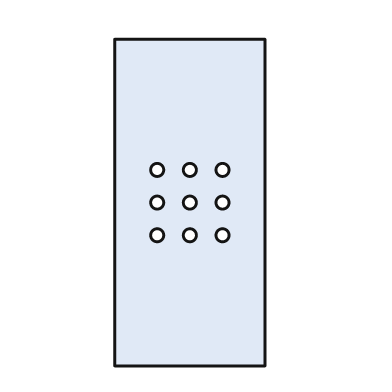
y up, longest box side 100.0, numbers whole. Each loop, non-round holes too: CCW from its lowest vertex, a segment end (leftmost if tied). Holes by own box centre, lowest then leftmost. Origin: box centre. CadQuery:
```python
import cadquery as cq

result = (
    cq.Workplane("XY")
    .moveTo(-23.0, -50.0)
    .lineTo(23.0, -50.0)
    .lineTo(23.0, 50.0)
    .lineTo(-23.0, 50.0)
    .close()
    .moveTo(-10.0, -10.0)
    .circle(2.0)
    .moveTo(0.0, -10.0)
    .circle(2.0)
    .moveTo(10.0, -10.0)
    .circle(2.0)
    .moveTo(-10.0, 0.0)
    .circle(2.0)
    .moveTo(0.0, 0.0)
    .circle(2.0)
    .moveTo(10.0, 0.0)
    .circle(2.0)
    .moveTo(-10.0, 10.0)
    .circle(2.0)
    .moveTo(0.0, 10.0)
    .circle(2.0)
    .moveTo(10.0, 10.0)
    .circle(2.0)
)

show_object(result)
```